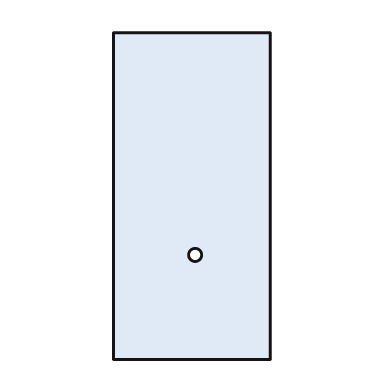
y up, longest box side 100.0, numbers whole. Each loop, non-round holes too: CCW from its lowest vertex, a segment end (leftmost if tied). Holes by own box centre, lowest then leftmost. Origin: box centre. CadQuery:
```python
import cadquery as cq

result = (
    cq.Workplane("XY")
    .moveTo(-24.0, -50.0)
    .lineTo(24.0, -50.0)
    .lineTo(24.0, 50.0)
    .lineTo(-24.0, 50.0)
    .close()
    .moveTo(1.0, -18.0)
    .circle(2.0)
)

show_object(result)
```